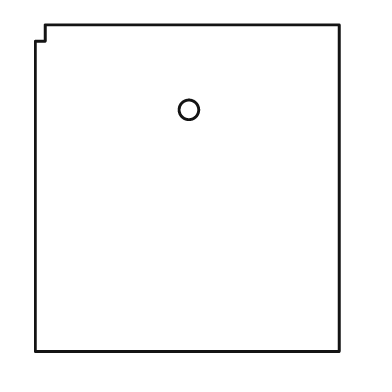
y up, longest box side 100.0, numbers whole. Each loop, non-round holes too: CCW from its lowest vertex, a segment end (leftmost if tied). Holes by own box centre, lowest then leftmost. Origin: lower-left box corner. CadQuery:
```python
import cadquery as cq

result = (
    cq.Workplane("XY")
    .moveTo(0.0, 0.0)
    .lineTo(93.0, 0.0)
    .lineTo(93.0, 100.0)
    .lineTo(3.0, 100.0)
    .lineTo(3.0, 95.0)
    .lineTo(0.0, 95.0)
    .close()
    .moveTo(47.0, 74.0)
    .circle(3.0)
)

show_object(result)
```